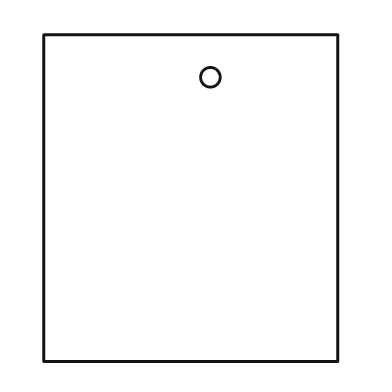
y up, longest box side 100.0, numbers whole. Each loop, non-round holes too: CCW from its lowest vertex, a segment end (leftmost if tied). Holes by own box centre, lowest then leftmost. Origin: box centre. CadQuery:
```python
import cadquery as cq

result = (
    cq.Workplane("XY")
    .moveTo(-45.0, -50.0)
    .lineTo(45.0, -50.0)
    .lineTo(45.0, 50.0)
    .lineTo(-45.0, 50.0)
    .close()
    .moveTo(6.0, 37.0)
    .circle(3.0)
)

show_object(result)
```